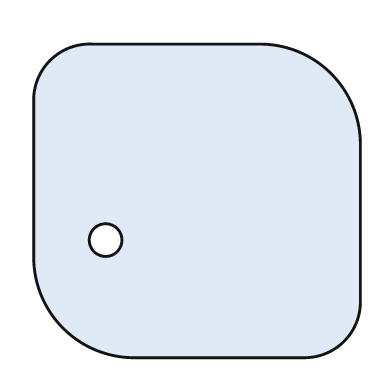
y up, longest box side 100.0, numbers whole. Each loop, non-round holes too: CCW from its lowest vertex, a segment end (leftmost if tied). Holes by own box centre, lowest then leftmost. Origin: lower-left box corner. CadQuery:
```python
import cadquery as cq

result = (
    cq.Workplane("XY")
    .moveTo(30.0, 0.0)
    .lineTo(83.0, 0.0)
    .threePointArc((95.0, 5.0), (100.0, 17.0))
    .lineTo(100.0, 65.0)
    .threePointArc((91.0, 87.0), (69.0, 96.0))
    .lineTo(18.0, 96.0)
    .threePointArc((5.0, 91.0), (0.0, 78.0))
    .lineTo(0.0, 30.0)
    .threePointArc((9.0, 9.0), (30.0, 0.0))
    .close()
    .moveTo(22.0, 36.0)
    .circle(5.0)
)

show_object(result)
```